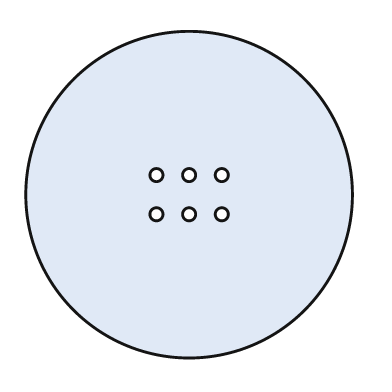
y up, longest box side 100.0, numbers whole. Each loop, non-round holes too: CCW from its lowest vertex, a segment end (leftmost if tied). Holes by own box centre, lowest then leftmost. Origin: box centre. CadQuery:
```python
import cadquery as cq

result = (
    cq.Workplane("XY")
    .moveTo(0.0, 0.0)
    .circle(50.0)
    .moveTo(-10.0, -6.0)
    .circle(2.0)
    .moveTo(0.0, -6.0)
    .circle(2.0)
    .moveTo(10.0, -6.0)
    .circle(2.0)
    .moveTo(-10.0, 6.0)
    .circle(2.0)
    .moveTo(0.0, 6.0)
    .circle(2.0)
    .moveTo(10.0, 6.0)
    .circle(2.0)
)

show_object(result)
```